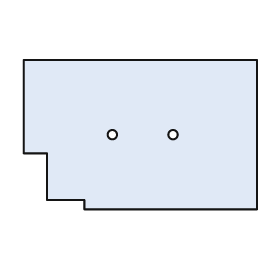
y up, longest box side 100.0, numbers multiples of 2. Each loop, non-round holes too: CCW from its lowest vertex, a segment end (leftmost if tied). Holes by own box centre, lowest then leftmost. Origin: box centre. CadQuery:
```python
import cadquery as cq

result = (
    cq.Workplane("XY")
    .moveTo(-24.0, -32.0)
    .lineTo(50.0, -32.0)
    .lineTo(50.0, 32.0)
    .lineTo(-50.0, 32.0)
    .lineTo(-50.0, -8.0)
    .lineTo(-40.0, -8.0)
    .lineTo(-40.0, -28.0)
    .lineTo(-24.0, -28.0)
    .close()
    .moveTo(-12.0, 0.0)
    .circle(2.0)
    .moveTo(14.0, 0.0)
    .circle(2.0)
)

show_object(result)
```